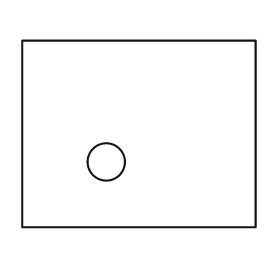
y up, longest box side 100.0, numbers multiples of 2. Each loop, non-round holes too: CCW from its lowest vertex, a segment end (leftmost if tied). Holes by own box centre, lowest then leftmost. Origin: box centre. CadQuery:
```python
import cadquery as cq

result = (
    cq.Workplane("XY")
    .moveTo(-50.0, -40.0)
    .lineTo(50.0, -40.0)
    .lineTo(50.0, 40.0)
    .lineTo(-50.0, 40.0)
    .close()
    .moveTo(-14.0, -12.0)
    .circle(8.0)
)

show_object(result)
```